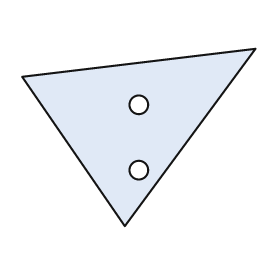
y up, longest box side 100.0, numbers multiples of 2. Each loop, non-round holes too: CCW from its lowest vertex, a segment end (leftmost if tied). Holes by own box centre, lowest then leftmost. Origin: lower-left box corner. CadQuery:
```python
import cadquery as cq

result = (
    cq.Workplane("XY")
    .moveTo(44.0, 0.0)
    .lineTo(100.0, 76.0)
    .lineTo(0.0, 64.0)
    .close()
    .moveTo(50.0, 24.0)
    .circle(4.0)
    .moveTo(50.0, 52.0)
    .circle(4.0)
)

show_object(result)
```